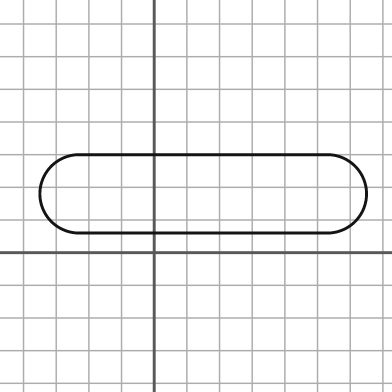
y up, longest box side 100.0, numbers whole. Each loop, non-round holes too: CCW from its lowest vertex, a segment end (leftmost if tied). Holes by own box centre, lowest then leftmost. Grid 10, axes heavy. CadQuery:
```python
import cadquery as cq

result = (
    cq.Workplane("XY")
    .moveTo(-23.0, 6.0)
    .lineTo(53.0, 6.0)
    .threePointArc((65.0, 18.0), (53.0, 30.0))
    .lineTo(-23.0, 30.0)
    .threePointArc((-35.0, 18.0), (-23.0, 6.0))
    .close()
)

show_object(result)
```